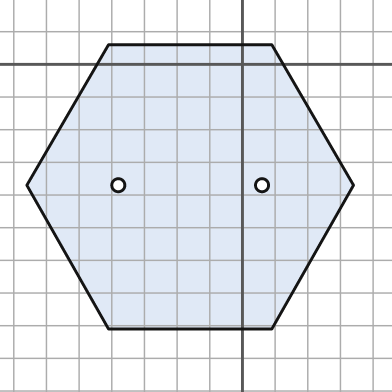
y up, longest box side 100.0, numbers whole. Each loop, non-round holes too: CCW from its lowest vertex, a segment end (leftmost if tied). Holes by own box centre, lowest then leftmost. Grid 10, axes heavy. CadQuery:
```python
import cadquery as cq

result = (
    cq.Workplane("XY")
    .moveTo(-41.0, -81.0)
    .lineTo(9.0, -81.0)
    .lineTo(34.0, -37.0)
    .lineTo(9.0, 6.0)
    .lineTo(-41.0, 6.0)
    .lineTo(-66.0, -37.0)
    .close()
    .moveTo(-38.0, -37.0)
    .circle(2.0)
    .moveTo(6.0, -37.0)
    .circle(2.0)
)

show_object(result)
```